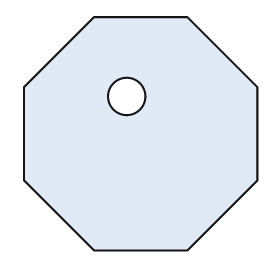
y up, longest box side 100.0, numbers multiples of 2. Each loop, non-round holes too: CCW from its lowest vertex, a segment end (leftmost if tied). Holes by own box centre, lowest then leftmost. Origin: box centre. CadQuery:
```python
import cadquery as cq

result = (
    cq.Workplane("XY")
    .moveTo(-20.0, -50.0)
    .lineTo(20.0, -50.0)
    .lineTo(50.0, -20.0)
    .lineTo(50.0, 20.0)
    .lineTo(20.0, 50.0)
    .lineTo(-20.0, 50.0)
    .lineTo(-50.0, 20.0)
    .lineTo(-50.0, -20.0)
    .close()
    .moveTo(-6.0, 16.0)
    .circle(8.0)
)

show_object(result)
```